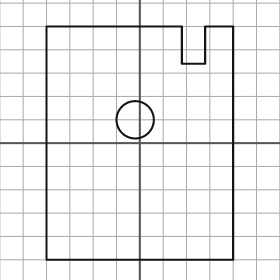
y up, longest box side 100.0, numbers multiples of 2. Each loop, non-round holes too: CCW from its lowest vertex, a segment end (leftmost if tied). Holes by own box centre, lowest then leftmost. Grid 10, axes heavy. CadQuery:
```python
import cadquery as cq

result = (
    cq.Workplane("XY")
    .moveTo(-40.0, -50.0)
    .lineTo(40.0, -50.0)
    .lineTo(40.0, 50.0)
    .lineTo(28.0, 50.0)
    .lineTo(28.0, 34.0)
    .lineTo(18.0, 34.0)
    .lineTo(18.0, 50.0)
    .lineTo(-40.0, 50.0)
    .close()
    .moveTo(-2.0, 10.0)
    .circle(8.0)
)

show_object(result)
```